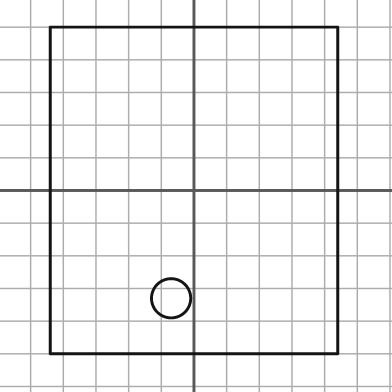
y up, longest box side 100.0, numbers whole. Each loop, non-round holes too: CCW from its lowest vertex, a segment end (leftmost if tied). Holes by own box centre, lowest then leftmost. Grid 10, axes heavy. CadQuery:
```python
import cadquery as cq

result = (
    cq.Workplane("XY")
    .moveTo(-44.0, -50.0)
    .lineTo(44.0, -50.0)
    .lineTo(44.0, 50.0)
    .lineTo(-44.0, 50.0)
    .close()
    .moveTo(-7.0, -33.0)
    .circle(6.0)
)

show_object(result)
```